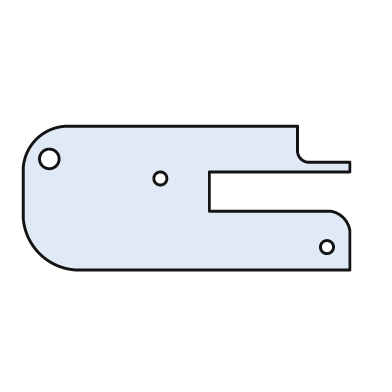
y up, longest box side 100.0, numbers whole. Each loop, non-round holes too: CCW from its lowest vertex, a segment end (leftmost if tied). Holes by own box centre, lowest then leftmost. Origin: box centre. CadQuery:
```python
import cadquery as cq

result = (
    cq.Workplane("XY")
    .moveTo(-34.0, -22.0)
    .lineTo(50.0, -22.0)
    .lineTo(50.0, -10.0)
    .threePointArc((48.0, -6.0), (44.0, -4.0))
    .lineTo(7.0, -4.0)
    .lineTo(7.0, 8.0)
    .lineTo(50.0, 8.0)
    .lineTo(50.0, 11.0)
    .lineTo(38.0, 11.0)
    .threePointArc((35.0, 12.0), (34.0, 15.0))
    .lineTo(34.0, 22.0)
    .lineTo(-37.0, 22.0)
    .threePointArc((-46.0, 18.0), (-50.0, 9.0))
    .lineTo(-50.0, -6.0)
    .threePointArc((-45.0, -17.0), (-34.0, -22.0))
    .close()
    .moveTo(43.0, -15.0)
    .circle(2.0)
    .moveTo(-8.0, 6.0)
    .circle(2.0)
    .moveTo(-42.0, 12.0)
    .circle(3.0)
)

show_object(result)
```